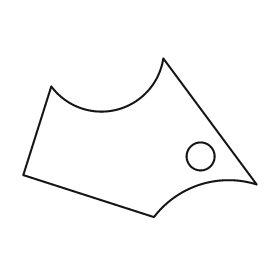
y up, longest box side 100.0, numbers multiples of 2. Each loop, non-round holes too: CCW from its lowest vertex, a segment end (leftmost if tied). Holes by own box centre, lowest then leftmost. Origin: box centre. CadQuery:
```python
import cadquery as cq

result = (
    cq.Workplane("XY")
    .moveTo(6.0, -34.0)
    .threePointArc((26.0, -20.0), (50.0, -20.0))
    .lineTo(10.0, 34.0)
    .threePointArc((-10.0, 12.0), (-38.0, 22.0))
    .lineTo(-50.0, -16.0)
    .close()
    .moveTo(26.0, -8.0)
    .circle(6.0)
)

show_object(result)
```